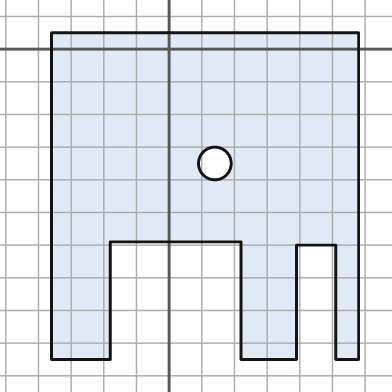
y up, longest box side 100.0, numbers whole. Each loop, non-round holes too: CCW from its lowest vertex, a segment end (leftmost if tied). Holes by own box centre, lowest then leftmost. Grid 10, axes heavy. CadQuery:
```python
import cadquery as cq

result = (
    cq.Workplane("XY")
    .moveTo(-36.0, -95.0)
    .lineTo(-18.0, -95.0)
    .lineTo(-18.0, -59.0)
    .lineTo(22.0, -59.0)
    .lineTo(22.0, -95.0)
    .lineTo(39.0, -95.0)
    .lineTo(39.0, -60.0)
    .lineTo(51.0, -60.0)
    .lineTo(51.0, -95.0)
    .lineTo(58.0, -95.0)
    .lineTo(58.0, 5.0)
    .lineTo(-36.0, 5.0)
    .close()
    .moveTo(14.0, -35.0)
    .circle(5.0)
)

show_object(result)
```